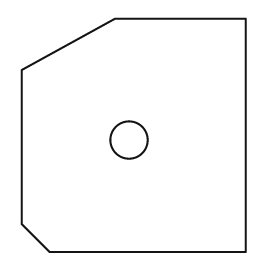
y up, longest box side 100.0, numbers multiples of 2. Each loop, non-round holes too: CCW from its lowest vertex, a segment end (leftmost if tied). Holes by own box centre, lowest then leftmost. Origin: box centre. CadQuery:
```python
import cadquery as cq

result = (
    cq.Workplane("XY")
    .moveTo(-36.0, -50.0)
    .lineTo(48.0, -50.0)
    .lineTo(48.0, 50.0)
    .lineTo(-8.0, 50.0)
    .lineTo(-48.0, 28.0)
    .lineTo(-48.0, -38.0)
    .close()
    .moveTo(-2.0, -2.0)
    .circle(8.0)
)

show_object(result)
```